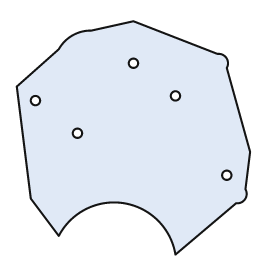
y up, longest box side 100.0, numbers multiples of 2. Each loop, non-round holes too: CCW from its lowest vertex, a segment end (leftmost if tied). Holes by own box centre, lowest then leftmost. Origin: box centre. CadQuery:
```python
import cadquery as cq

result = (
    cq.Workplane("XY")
    .moveTo(18.0, -50.0)
    .lineTo(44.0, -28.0)
    .threePointArc((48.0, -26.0), (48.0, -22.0))
    .lineTo(50.0, -6.0)
    .lineTo(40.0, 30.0)
    .threePointArc((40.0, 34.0), (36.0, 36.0))
    .lineTo(0.0, 50.0)
    .lineTo(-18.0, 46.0)
    .threePointArc((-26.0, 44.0), (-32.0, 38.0))
    .lineTo(-50.0, 22.0)
    .lineTo(-44.0, -26.0)
    .lineTo(-32.0, -42.0)
    .threePointArc((-4.0, -28.0), (18.0, -50.0))
    .close()
    .moveTo(40.0, -16.0)
    .circle(2.0)
    .moveTo(-24.0, 2.0)
    .circle(2.0)
    .moveTo(-42.0, 16.0)
    .circle(2.0)
    .moveTo(18.0, 18.0)
    .circle(2.0)
    .moveTo(0.0, 32.0)
    .circle(2.0)
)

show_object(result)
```